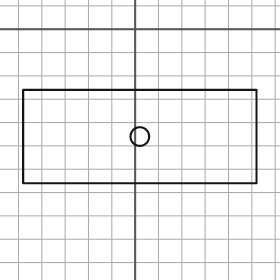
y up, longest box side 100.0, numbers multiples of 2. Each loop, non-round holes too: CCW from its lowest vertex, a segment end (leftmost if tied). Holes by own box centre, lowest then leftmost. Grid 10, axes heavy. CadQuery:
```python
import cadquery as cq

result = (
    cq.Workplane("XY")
    .moveTo(-48.0, -66.0)
    .lineTo(52.0, -66.0)
    .lineTo(52.0, -26.0)
    .lineTo(-48.0, -26.0)
    .close()
    .moveTo(2.0, -46.0)
    .circle(4.0)
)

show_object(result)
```